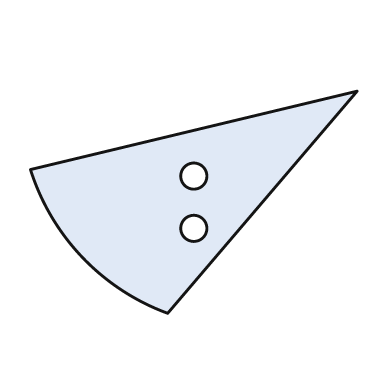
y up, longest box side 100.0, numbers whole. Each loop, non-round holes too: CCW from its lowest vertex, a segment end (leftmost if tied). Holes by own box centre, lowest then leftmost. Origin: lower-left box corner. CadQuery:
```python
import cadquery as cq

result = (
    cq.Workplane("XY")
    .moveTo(42.0, 0.0)
    .lineTo(100.0, 68.0)
    .lineTo(0.0, 44.0)
    .threePointArc((16.0, 17.0), (42.0, 0.0))
    .close()
    .moveTo(50.0, 26.0)
    .circle(4.0)
    .moveTo(50.0, 42.0)
    .circle(4.0)
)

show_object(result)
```